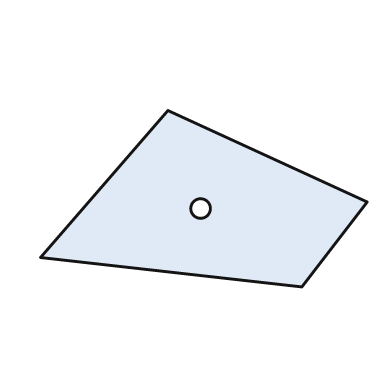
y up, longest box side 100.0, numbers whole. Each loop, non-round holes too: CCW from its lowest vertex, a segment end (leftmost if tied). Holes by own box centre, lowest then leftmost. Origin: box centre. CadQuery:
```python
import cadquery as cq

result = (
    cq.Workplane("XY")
    .moveTo(30.0, -27.0)
    .lineTo(50.0, -1.0)
    .lineTo(-11.0, 27.0)
    .lineTo(-50.0, -18.0)
    .close()
    .moveTo(-1.0, -3.0)
    .circle(3.0)
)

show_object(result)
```